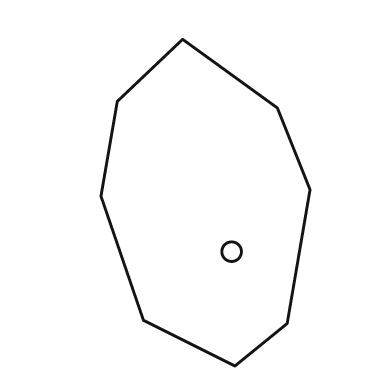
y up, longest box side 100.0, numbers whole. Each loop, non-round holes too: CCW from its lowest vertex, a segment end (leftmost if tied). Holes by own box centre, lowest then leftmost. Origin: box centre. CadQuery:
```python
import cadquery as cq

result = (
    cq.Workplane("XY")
    .moveTo(9.0, -50.0)
    .lineTo(25.0, -37.0)
    .lineTo(32.0, 4.0)
    .lineTo(22.0, 29.0)
    .lineTo(-7.0, 50.0)
    .lineTo(-27.0, 31.0)
    .lineTo(-32.0, 2.0)
    .lineTo(-19.0, -36.0)
    .close()
    .moveTo(8.0, -15.0)
    .circle(3.0)
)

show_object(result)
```